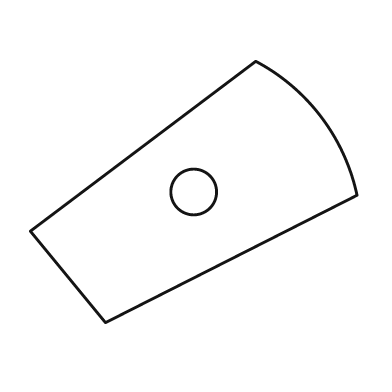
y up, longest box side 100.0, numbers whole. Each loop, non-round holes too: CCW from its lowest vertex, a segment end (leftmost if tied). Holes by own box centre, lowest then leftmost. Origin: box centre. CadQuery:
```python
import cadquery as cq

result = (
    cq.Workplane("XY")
    .moveTo(-27.0, -40.0)
    .lineTo(50.0, -1.0)
    .threePointArc((39.0, 23.0), (19.0, 40.0))
    .lineTo(-50.0, -12.0)
    .close()
    .moveTo(0.0, 0.0)
    .circle(7.0)
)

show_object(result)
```